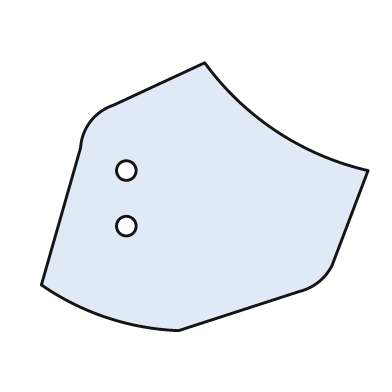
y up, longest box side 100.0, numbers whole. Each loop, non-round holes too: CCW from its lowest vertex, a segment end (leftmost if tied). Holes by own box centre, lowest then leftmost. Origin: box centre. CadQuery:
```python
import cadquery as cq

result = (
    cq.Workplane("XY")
    .moveTo(-8.0, -41.0)
    .lineTo(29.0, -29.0)
    .threePointArc((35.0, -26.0), (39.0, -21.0))
    .lineTo(50.0, 8.0)
    .threePointArc((22.0, 20.0), (0.0, 41.0))
    .lineTo(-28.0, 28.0)
    .threePointArc((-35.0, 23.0), (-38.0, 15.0))
    .lineTo(-50.0, -27.0)
    .threePointArc((-30.0, -37.0), (-8.0, -41.0))
    .close()
    .moveTo(-24.0, -9.0)
    .circle(3.0)
    .moveTo(-24.0, 8.0)
    .circle(3.0)
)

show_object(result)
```